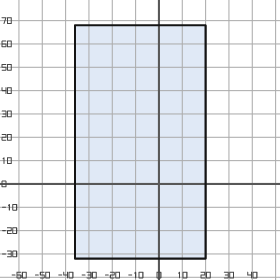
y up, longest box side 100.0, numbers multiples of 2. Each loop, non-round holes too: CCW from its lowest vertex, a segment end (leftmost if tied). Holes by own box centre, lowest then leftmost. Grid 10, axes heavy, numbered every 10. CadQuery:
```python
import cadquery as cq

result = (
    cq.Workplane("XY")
    .moveTo(-36.0, -32.0)
    .lineTo(20.0, -32.0)
    .lineTo(20.0, 68.0)
    .lineTo(-36.0, 68.0)
    .close()
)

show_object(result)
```